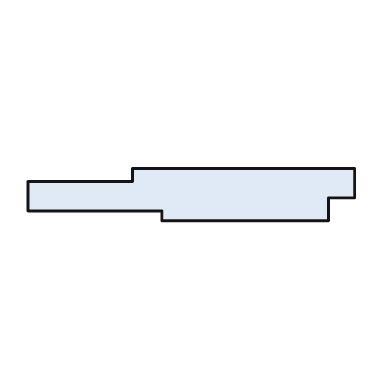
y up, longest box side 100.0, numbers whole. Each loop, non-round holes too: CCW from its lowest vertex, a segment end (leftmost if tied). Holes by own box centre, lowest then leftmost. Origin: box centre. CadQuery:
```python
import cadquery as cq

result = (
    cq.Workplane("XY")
    .moveTo(-9.0, -8.0)
    .lineTo(42.0, -8.0)
    .lineTo(42.0, -1.0)
    .lineTo(50.0, -1.0)
    .lineTo(50.0, 8.0)
    .lineTo(-18.0, 8.0)
    .lineTo(-18.0, 4.0)
    .lineTo(-50.0, 4.0)
    .lineTo(-50.0, -5.0)
    .lineTo(-9.0, -5.0)
    .close()
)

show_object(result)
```